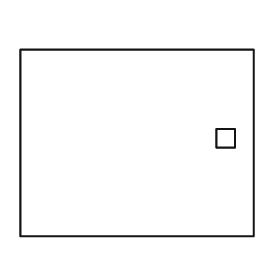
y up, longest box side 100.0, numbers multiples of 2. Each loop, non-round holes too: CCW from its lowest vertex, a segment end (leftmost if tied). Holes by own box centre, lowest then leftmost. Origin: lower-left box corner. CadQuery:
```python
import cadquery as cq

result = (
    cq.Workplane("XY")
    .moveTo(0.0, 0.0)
    .lineTo(100.0, 0.0)
    .lineTo(100.0, 80.0)
    .lineTo(0.0, 80.0)
    .close()
    .moveTo(84.0, 38.0)
    .lineTo(92.0, 38.0)
    .lineTo(92.0, 46.0)
    .lineTo(84.0, 46.0)
    .close()
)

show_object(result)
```